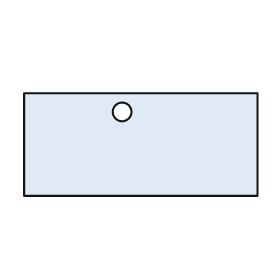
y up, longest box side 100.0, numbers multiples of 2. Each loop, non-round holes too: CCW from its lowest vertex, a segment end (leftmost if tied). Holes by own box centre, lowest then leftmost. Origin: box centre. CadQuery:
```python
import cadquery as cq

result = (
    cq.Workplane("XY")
    .moveTo(-50.0, -22.0)
    .lineTo(50.0, -22.0)
    .lineTo(50.0, 22.0)
    .lineTo(-50.0, 22.0)
    .close()
    .moveTo(-8.0, 14.0)
    .circle(4.0)
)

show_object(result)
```